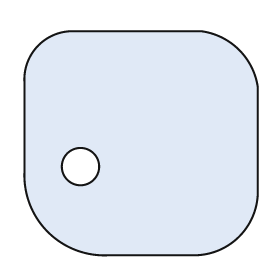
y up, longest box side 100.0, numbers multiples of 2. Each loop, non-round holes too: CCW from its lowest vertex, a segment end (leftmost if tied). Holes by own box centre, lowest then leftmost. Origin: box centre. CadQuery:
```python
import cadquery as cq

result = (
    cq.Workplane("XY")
    .moveTo(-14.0, -48.0)
    .lineTo(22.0, -48.0)
    .threePointArc((42.0, -40.0), (50.0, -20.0))
    .lineTo(50.0, 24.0)
    .threePointArc((42.0, 40.0), (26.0, 48.0))
    .lineTo(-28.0, 48.0)
    .threePointArc((-44.0, 42.0), (-50.0, 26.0))
    .lineTo(-50.0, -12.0)
    .threePointArc((-40.0, -38.0), (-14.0, -48.0))
    .close()
    .moveTo(-26.0, -10.0)
    .circle(8.0)
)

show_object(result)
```